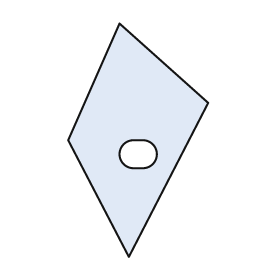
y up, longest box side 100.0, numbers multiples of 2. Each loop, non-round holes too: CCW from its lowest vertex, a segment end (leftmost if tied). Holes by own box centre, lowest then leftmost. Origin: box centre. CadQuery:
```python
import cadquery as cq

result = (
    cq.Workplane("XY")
    .moveTo(-4.0, -50.0)
    .lineTo(30.0, 16.0)
    .lineTo(-8.0, 50.0)
    .lineTo(-30.0, 0.0)
    .close()
    .moveTo(-2.0, -12.0)
    .lineTo(2.0, -12.0)
    .threePointArc((8.0, -6.0), (2.0, 0.0))
    .lineTo(-2.0, 0.0)
    .threePointArc((-8.0, -6.0), (-2.0, -12.0))
    .close()
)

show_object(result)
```